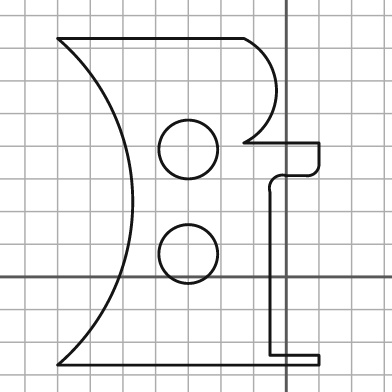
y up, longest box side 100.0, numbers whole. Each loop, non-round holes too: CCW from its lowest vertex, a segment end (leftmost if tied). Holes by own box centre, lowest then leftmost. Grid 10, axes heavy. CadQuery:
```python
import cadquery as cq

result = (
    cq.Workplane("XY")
    .moveTo(-70.0, -27.0)
    .lineTo(10.0, -27.0)
    .lineTo(10.0, -24.0)
    .lineTo(-5.0, -24.0)
    .lineTo(-5.0, 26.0)
    .threePointArc((-4.0, 30.0), (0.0, 31.0))
    .lineTo(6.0, 31.0)
    .threePointArc((9.0, 32.0), (10.0, 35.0))
    .lineTo(10.0, 41.0)
    .lineTo(-13.0, 41.0)
    .threePointArc((-3.0, 57.0), (-13.0, 73.0))
    .lineTo(-70.0, 73.0)
    .threePointArc((-47.0, 23.0), (-70.0, -27.0))
    .close()
    .moveTo(-30.0, 7.0)
    .circle(9.0)
    .moveTo(-30.0, 39.0)
    .circle(9.0)
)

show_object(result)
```